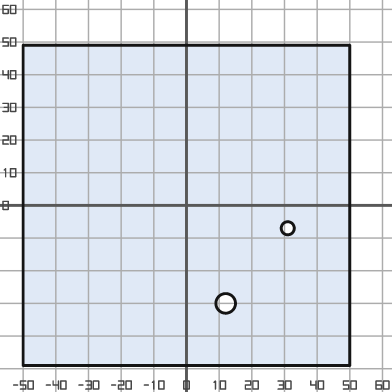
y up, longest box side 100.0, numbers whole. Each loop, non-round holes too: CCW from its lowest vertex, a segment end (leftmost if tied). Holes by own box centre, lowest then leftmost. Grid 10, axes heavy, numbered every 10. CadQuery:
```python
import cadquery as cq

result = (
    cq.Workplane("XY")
    .moveTo(-50.0, -49.0)
    .lineTo(50.0, -49.0)
    .lineTo(50.0, 49.0)
    .lineTo(-50.0, 49.0)
    .close()
    .moveTo(12.0, -30.0)
    .circle(3.0)
    .moveTo(31.0, -7.0)
    .circle(2.0)
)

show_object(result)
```